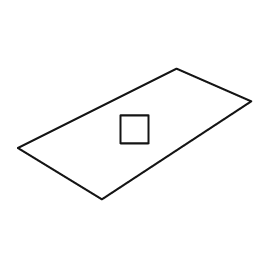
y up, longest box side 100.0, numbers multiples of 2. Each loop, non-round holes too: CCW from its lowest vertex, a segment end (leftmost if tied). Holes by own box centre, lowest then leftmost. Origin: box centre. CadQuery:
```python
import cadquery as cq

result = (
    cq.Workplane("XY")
    .moveTo(-14.0, -28.0)
    .lineTo(50.0, 14.0)
    .lineTo(18.0, 28.0)
    .lineTo(-50.0, -6.0)
    .close()
    .moveTo(-6.0, -4.0)
    .lineTo(6.0, -4.0)
    .lineTo(6.0, 8.0)
    .lineTo(-6.0, 8.0)
    .close()
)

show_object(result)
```